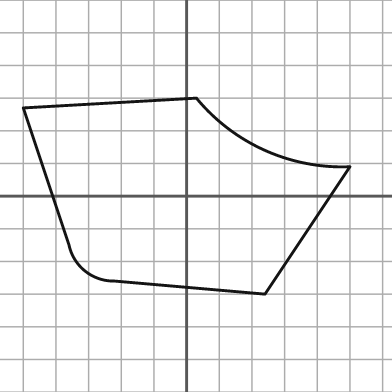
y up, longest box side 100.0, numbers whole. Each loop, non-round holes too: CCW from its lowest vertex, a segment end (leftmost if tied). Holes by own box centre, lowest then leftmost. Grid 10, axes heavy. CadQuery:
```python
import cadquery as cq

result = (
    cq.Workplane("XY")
    .moveTo(24.0, -30.0)
    .lineTo(50.0, 9.0)
    .threePointArc((24.0, 14.0), (3.0, 30.0))
    .lineTo(-50.0, 27.0)
    .lineTo(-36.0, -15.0)
    .threePointArc((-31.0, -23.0), (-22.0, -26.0))
    .close()
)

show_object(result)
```